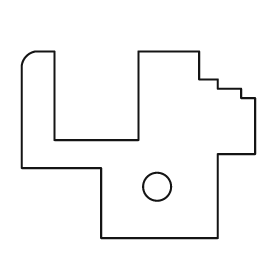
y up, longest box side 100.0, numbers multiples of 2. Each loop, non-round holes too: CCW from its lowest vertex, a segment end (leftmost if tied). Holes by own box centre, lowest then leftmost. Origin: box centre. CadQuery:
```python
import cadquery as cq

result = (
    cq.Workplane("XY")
    .moveTo(-16.0, -40.0)
    .lineTo(34.0, -40.0)
    .lineTo(34.0, -4.0)
    .lineTo(50.0, -4.0)
    .lineTo(50.0, 20.0)
    .lineTo(44.0, 20.0)
    .lineTo(44.0, 24.0)
    .lineTo(34.0, 24.0)
    .lineTo(34.0, 28.0)
    .lineTo(26.0, 28.0)
    .lineTo(26.0, 40.0)
    .lineTo(0.0, 40.0)
    .lineTo(0.0, 2.0)
    .lineTo(-36.0, 2.0)
    .lineTo(-36.0, 40.0)
    .lineTo(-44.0, 40.0)
    .threePointArc((-48.0, 38.0), (-50.0, 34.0))
    .lineTo(-50.0, -10.0)
    .lineTo(-16.0, -10.0)
    .close()
    .moveTo(8.0, -18.0)
    .circle(6.0)
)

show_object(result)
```